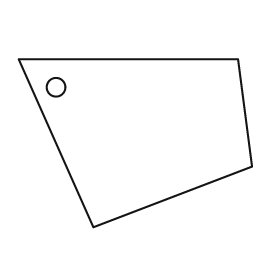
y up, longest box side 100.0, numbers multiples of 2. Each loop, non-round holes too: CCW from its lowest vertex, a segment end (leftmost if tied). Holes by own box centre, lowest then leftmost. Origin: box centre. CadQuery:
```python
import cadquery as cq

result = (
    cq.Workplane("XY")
    .moveTo(-18.0, -36.0)
    .lineTo(50.0, -10.0)
    .lineTo(44.0, 36.0)
    .lineTo(-50.0, 36.0)
    .close()
    .moveTo(-34.0, 24.0)
    .circle(4.0)
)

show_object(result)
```